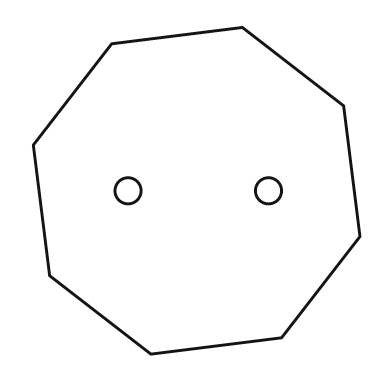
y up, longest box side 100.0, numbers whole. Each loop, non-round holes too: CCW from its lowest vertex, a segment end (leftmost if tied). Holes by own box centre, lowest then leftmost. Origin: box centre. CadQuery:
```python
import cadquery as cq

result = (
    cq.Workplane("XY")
    .moveTo(-14.0, -50.0)
    .lineTo(26.0, -45.0)
    .lineTo(50.0, -14.0)
    .lineTo(45.0, 26.0)
    .lineTo(14.0, 50.0)
    .lineTo(-26.0, 45.0)
    .lineTo(-50.0, 14.0)
    .lineTo(-45.0, -26.0)
    .close()
    .moveTo(-21.0, 0.0)
    .circle(4.0)
    .moveTo(22.0, 0.0)
    .circle(4.0)
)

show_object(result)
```